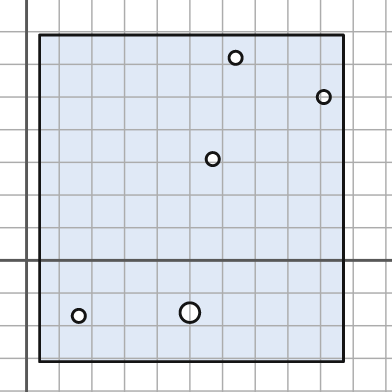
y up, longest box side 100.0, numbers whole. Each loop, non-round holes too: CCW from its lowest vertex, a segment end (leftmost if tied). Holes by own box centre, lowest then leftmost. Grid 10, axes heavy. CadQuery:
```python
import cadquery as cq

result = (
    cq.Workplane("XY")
    .moveTo(4.0, -31.0)
    .lineTo(97.0, -31.0)
    .lineTo(97.0, 69.0)
    .lineTo(4.0, 69.0)
    .close()
    .moveTo(16.0, -17.0)
    .circle(2.0)
    .moveTo(50.0, -16.0)
    .circle(3.0)
    .moveTo(57.0, 31.0)
    .circle(2.0)
    .moveTo(91.0, 50.0)
    .circle(2.0)
    .moveTo(64.0, 62.0)
    .circle(2.0)
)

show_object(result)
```